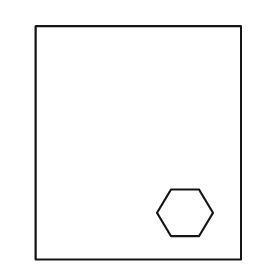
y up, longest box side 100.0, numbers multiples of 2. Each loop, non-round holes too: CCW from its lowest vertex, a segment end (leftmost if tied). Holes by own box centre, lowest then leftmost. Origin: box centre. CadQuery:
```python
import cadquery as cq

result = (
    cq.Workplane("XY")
    .moveTo(-44.0, -50.0)
    .lineTo(44.0, -50.0)
    .lineTo(44.0, 50.0)
    .lineTo(-44.0, 50.0)
    .close()
    .moveTo(14.0, -40.0)
    .lineTo(26.0, -40.0)
    .lineTo(32.0, -30.0)
    .lineTo(26.0, -20.0)
    .lineTo(14.0, -20.0)
    .lineTo(8.0, -30.0)
    .close()
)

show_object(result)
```